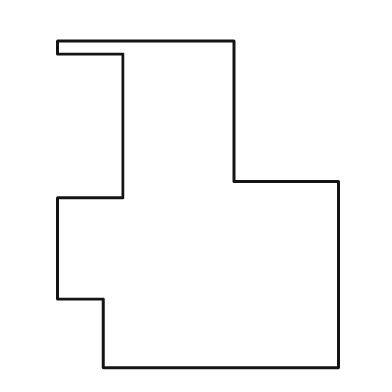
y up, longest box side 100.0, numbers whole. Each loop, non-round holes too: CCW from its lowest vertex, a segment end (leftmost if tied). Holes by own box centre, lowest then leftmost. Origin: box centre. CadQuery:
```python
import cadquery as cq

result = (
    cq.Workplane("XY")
    .moveTo(-29.0, -50.0)
    .lineTo(43.0, -50.0)
    .lineTo(43.0, 7.0)
    .lineTo(11.0, 7.0)
    .lineTo(11.0, 50.0)
    .lineTo(-43.0, 50.0)
    .lineTo(-43.0, 46.0)
    .lineTo(-23.0, 46.0)
    .lineTo(-23.0, 2.0)
    .lineTo(-43.0, 2.0)
    .lineTo(-43.0, -29.0)
    .lineTo(-29.0, -29.0)
    .close()
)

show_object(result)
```